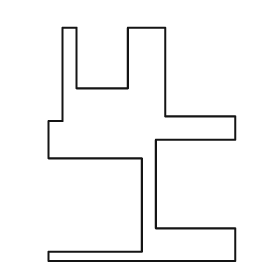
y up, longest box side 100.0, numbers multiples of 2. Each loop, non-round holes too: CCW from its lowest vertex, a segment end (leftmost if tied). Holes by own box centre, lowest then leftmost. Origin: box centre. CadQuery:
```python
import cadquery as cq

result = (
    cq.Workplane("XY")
    .moveTo(-40.0, -50.0)
    .lineTo(40.0, -50.0)
    .lineTo(40.0, -36.0)
    .lineTo(6.0, -36.0)
    .lineTo(6.0, 2.0)
    .lineTo(40.0, 2.0)
    .lineTo(40.0, 12.0)
    .lineTo(10.0, 12.0)
    .lineTo(10.0, 50.0)
    .lineTo(-6.0, 50.0)
    .lineTo(-6.0, 24.0)
    .lineTo(-28.0, 24.0)
    .lineTo(-28.0, 50.0)
    .lineTo(-34.0, 50.0)
    .lineTo(-34.0, 10.0)
    .lineTo(-40.0, 10.0)
    .lineTo(-40.0, -6.0)
    .lineTo(0.0, -6.0)
    .lineTo(0.0, -46.0)
    .lineTo(-40.0, -46.0)
    .close()
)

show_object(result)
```